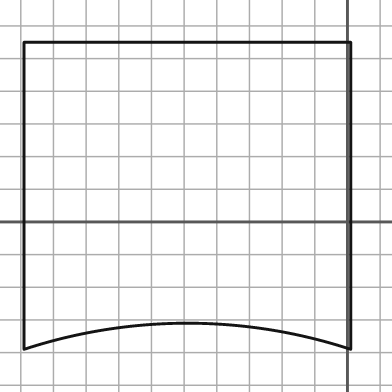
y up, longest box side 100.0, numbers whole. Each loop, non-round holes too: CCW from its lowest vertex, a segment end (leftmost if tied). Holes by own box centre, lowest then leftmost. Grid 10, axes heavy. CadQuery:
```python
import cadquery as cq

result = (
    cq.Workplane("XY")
    .moveTo(-99.0, -39.0)
    .threePointArc((-49.0, -31.0), (1.0, -39.0))
    .lineTo(1.0, 55.0)
    .lineTo(-99.0, 55.0)
    .close()
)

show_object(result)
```